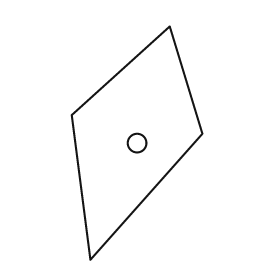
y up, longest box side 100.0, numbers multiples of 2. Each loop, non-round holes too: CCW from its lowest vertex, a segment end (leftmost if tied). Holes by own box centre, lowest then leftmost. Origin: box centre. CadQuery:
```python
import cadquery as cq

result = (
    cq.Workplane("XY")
    .moveTo(-20.0, -50.0)
    .lineTo(28.0, 4.0)
    .lineTo(14.0, 50.0)
    .lineTo(-28.0, 12.0)
    .close()
    .moveTo(0.0, 0.0)
    .circle(4.0)
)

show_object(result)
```